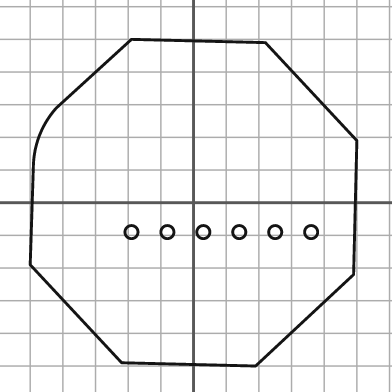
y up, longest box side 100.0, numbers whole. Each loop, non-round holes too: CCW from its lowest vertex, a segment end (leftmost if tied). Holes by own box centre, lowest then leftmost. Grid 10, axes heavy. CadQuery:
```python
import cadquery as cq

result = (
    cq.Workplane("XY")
    .moveTo(19.0, -50.0)
    .lineTo(49.0, -22.0)
    .lineTo(50.0, 19.0)
    .lineTo(22.0, 49.0)
    .lineTo(-19.0, 50.0)
    .lineTo(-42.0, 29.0)
    .threePointArc((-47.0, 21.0), (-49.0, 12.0))
    .lineTo(-50.0, -19.0)
    .lineTo(-22.0, -49.0)
    .close()
    .moveTo(-19.0, -9.0)
    .circle(2.0)
    .moveTo(-8.0, -9.0)
    .circle(2.0)
    .moveTo(3.0, -9.0)
    .circle(2.0)
    .moveTo(14.0, -9.0)
    .circle(2.0)
    .moveTo(25.0, -9.0)
    .circle(2.0)
    .moveTo(36.0, -9.0)
    .circle(2.0)
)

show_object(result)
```